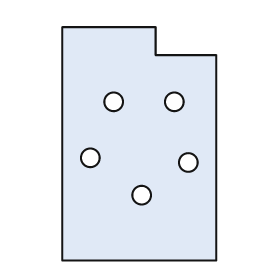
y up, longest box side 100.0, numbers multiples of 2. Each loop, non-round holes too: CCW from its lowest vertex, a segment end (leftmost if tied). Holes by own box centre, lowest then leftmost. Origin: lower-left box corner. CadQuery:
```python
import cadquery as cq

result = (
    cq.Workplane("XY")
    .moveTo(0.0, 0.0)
    .lineTo(66.0, 0.0)
    .lineTo(66.0, 88.0)
    .lineTo(40.0, 88.0)
    .lineTo(40.0, 100.0)
    .lineTo(0.0, 100.0)
    .close()
    .moveTo(34.0, 28.0)
    .circle(4.0)
    .moveTo(54.0, 42.0)
    .circle(4.0)
    .moveTo(12.0, 44.0)
    .circle(4.0)
    .moveTo(22.0, 68.0)
    .circle(4.0)
    .moveTo(48.0, 68.0)
    .circle(4.0)
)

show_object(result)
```